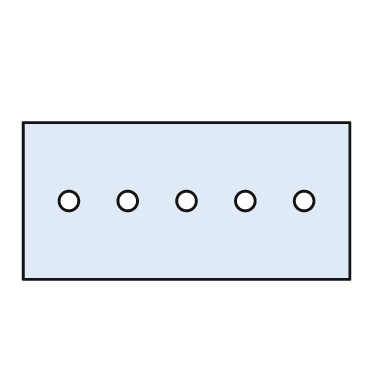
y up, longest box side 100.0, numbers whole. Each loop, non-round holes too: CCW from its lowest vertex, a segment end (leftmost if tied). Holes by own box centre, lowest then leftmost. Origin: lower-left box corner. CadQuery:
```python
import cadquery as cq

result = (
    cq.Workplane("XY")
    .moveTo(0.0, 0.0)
    .lineTo(100.0, 0.0)
    .lineTo(100.0, 48.0)
    .lineTo(0.0, 48.0)
    .close()
    .moveTo(14.0, 24.0)
    .circle(3.0)
    .moveTo(32.0, 24.0)
    .circle(3.0)
    .moveTo(50.0, 24.0)
    .circle(3.0)
    .moveTo(68.0, 24.0)
    .circle(3.0)
    .moveTo(86.0, 24.0)
    .circle(3.0)
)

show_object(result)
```